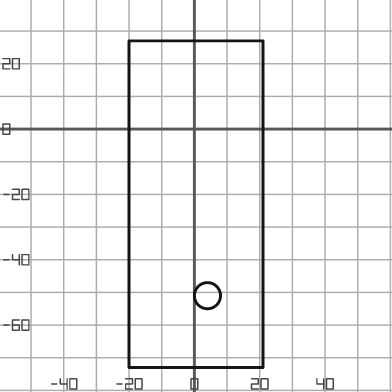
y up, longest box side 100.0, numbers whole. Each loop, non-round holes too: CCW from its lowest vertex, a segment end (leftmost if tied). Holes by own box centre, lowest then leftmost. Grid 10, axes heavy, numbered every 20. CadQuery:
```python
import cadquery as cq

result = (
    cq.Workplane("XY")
    .moveTo(-20.0, -73.0)
    .lineTo(21.0, -73.0)
    .lineTo(21.0, 27.0)
    .lineTo(-20.0, 27.0)
    .close()
    .moveTo(4.0, -51.0)
    .circle(4.0)
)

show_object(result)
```